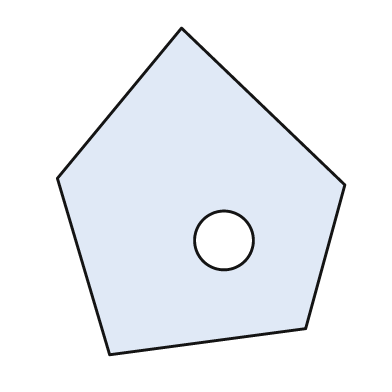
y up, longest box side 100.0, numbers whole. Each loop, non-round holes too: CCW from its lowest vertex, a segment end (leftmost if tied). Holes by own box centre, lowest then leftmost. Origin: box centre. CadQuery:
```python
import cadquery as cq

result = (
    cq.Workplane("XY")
    .moveTo(-28.0, -50.0)
    .lineTo(32.0, -42.0)
    .lineTo(44.0, 2.0)
    .lineTo(-6.0, 50.0)
    .lineTo(-44.0, 4.0)
    .close()
    .moveTo(7.0, -15.0)
    .circle(9.0)
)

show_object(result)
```